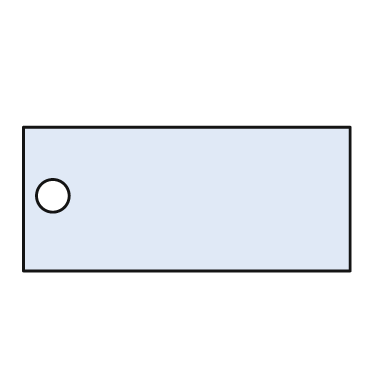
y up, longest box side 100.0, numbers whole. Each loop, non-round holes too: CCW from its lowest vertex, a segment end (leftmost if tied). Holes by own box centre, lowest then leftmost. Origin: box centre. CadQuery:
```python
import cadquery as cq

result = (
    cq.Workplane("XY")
    .moveTo(-50.0, -22.0)
    .lineTo(50.0, -22.0)
    .lineTo(50.0, 22.0)
    .lineTo(-50.0, 22.0)
    .close()
    .moveTo(-41.0, 1.0)
    .circle(5.0)
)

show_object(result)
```